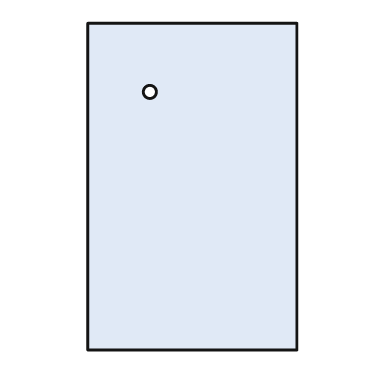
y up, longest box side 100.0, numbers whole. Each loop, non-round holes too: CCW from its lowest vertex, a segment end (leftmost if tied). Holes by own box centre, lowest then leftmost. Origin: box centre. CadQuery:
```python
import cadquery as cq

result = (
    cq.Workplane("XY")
    .moveTo(-32.0, -50.0)
    .lineTo(32.0, -50.0)
    .lineTo(32.0, 50.0)
    .lineTo(-32.0, 50.0)
    .close()
    .moveTo(-13.0, 29.0)
    .circle(2.0)
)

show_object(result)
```